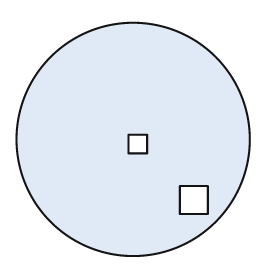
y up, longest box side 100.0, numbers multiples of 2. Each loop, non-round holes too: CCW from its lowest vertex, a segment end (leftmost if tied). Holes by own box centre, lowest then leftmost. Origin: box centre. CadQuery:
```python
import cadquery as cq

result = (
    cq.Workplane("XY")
    .moveTo(0.0, 0.0)
    .circle(50.0)
    .moveTo(20.0, -32.0)
    .lineTo(32.0, -32.0)
    .lineTo(32.0, -20.0)
    .lineTo(20.0, -20.0)
    .close()
    .moveTo(-2.0, -6.0)
    .lineTo(6.0, -6.0)
    .lineTo(6.0, 2.0)
    .lineTo(-2.0, 2.0)
    .close()
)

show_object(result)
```